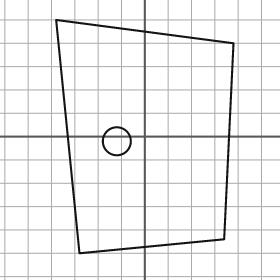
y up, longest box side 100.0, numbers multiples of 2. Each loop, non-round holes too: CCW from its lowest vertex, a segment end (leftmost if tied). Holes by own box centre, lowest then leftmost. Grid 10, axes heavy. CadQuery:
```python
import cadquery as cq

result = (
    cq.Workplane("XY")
    .moveTo(-28.0, -50.0)
    .lineTo(34.0, -44.0)
    .lineTo(38.0, 40.0)
    .lineTo(-38.0, 50.0)
    .close()
    .moveTo(-12.0, -2.0)
    .circle(6.0)
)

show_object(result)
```